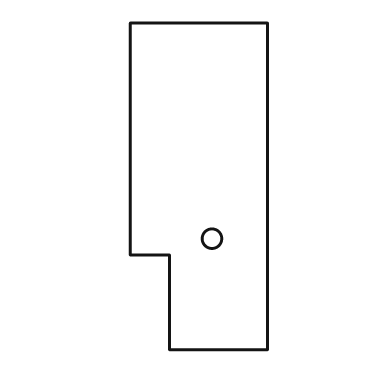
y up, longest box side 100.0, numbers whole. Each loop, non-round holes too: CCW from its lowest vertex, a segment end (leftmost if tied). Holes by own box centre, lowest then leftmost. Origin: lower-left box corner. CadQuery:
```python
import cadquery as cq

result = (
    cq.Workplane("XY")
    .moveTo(12.0, 0.0)
    .lineTo(42.0, 0.0)
    .lineTo(42.0, 100.0)
    .lineTo(0.0, 100.0)
    .lineTo(0.0, 29.0)
    .lineTo(12.0, 29.0)
    .close()
    .moveTo(25.0, 34.0)
    .circle(3.0)
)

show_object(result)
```